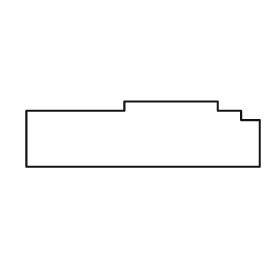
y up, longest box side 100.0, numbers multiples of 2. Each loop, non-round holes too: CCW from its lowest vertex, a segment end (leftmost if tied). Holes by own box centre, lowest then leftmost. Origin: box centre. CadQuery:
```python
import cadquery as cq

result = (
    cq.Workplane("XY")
    .moveTo(-50.0, -14.0)
    .lineTo(50.0, -14.0)
    .lineTo(50.0, 6.0)
    .lineTo(42.0, 6.0)
    .lineTo(42.0, 10.0)
    .lineTo(32.0, 10.0)
    .lineTo(32.0, 14.0)
    .lineTo(-8.0, 14.0)
    .lineTo(-8.0, 10.0)
    .lineTo(-50.0, 10.0)
    .close()
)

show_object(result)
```